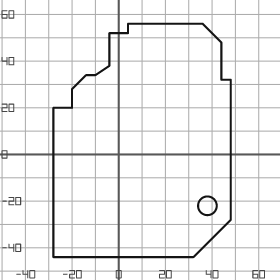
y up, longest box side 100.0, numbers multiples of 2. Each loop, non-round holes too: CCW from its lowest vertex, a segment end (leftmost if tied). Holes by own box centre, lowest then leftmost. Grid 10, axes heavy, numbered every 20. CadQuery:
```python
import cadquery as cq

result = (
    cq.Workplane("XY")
    .moveTo(-28.0, -44.0)
    .lineTo(32.0, -44.0)
    .lineTo(48.0, -28.0)
    .lineTo(48.0, 32.0)
    .lineTo(44.0, 32.0)
    .lineTo(44.0, 48.0)
    .lineTo(36.0, 56.0)
    .lineTo(4.0, 56.0)
    .lineTo(4.0, 52.0)
    .lineTo(-4.0, 52.0)
    .lineTo(-4.0, 38.0)
    .lineTo(-10.0, 34.0)
    .lineTo(-14.0, 34.0)
    .lineTo(-20.0, 28.0)
    .lineTo(-20.0, 20.0)
    .lineTo(-28.0, 20.0)
    .close()
    .moveTo(38.0, -22.0)
    .circle(4.0)
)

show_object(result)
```